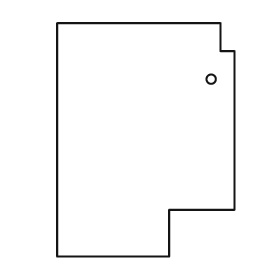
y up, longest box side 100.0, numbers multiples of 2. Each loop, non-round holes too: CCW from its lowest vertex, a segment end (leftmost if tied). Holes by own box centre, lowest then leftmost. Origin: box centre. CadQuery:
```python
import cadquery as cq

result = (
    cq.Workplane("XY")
    .moveTo(-38.0, -50.0)
    .lineTo(10.0, -50.0)
    .lineTo(10.0, -30.0)
    .lineTo(38.0, -30.0)
    .lineTo(38.0, 38.0)
    .lineTo(32.0, 38.0)
    .lineTo(32.0, 50.0)
    .lineTo(-38.0, 50.0)
    .close()
    .moveTo(28.0, 26.0)
    .circle(2.0)
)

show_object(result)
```